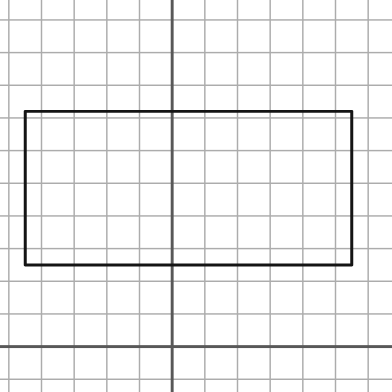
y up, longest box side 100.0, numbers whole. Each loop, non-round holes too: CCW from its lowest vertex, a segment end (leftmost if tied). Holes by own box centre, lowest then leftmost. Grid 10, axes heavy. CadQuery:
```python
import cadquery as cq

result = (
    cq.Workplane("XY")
    .moveTo(-45.0, 25.0)
    .lineTo(55.0, 25.0)
    .lineTo(55.0, 72.0)
    .lineTo(-45.0, 72.0)
    .close()
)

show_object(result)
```